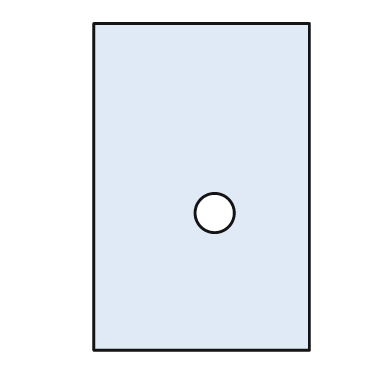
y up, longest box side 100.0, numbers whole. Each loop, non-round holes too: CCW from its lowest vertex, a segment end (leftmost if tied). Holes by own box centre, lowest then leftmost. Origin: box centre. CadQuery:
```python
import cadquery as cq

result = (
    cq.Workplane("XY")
    .moveTo(-33.0, -50.0)
    .lineTo(33.0, -50.0)
    .lineTo(33.0, 50.0)
    .lineTo(-33.0, 50.0)
    .close()
    .moveTo(4.0, -8.0)
    .circle(6.0)
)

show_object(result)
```